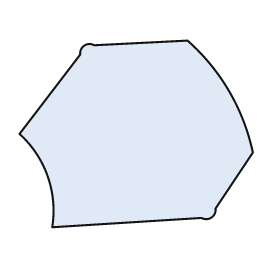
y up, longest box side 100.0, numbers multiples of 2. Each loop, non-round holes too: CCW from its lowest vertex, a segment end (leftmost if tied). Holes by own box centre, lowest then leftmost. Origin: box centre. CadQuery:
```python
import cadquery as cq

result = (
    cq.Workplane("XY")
    .moveTo(-36.0, -40.0)
    .lineTo(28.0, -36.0)
    .threePointArc((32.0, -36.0), (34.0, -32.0))
    .lineTo(50.0, -8.0)
    .threePointArc((40.0, 18.0), (22.0, 40.0))
    .lineTo(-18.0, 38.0)
    .threePointArc((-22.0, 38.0), (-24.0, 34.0))
    .lineTo(-50.0, 0.0)
    .threePointArc((-38.0, -18.0), (-36.0, -40.0))
    .close()
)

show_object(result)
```